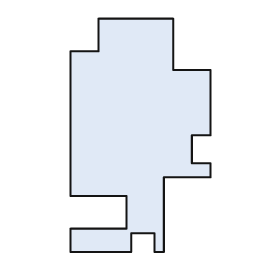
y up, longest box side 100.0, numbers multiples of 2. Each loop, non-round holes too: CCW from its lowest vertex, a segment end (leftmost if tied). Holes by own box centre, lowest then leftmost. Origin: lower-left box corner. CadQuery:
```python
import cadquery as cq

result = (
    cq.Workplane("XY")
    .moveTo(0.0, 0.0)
    .lineTo(26.0, 0.0)
    .lineTo(26.0, 8.0)
    .lineTo(36.0, 8.0)
    .lineTo(36.0, 0.0)
    .lineTo(40.0, 0.0)
    .lineTo(40.0, 32.0)
    .lineTo(60.0, 32.0)
    .lineTo(60.0, 38.0)
    .lineTo(52.0, 38.0)
    .lineTo(52.0, 50.0)
    .lineTo(60.0, 50.0)
    .lineTo(60.0, 78.0)
    .lineTo(44.0, 78.0)
    .lineTo(44.0, 100.0)
    .lineTo(12.0, 100.0)
    .lineTo(12.0, 86.0)
    .lineTo(0.0, 86.0)
    .lineTo(0.0, 24.0)
    .lineTo(24.0, 24.0)
    .lineTo(24.0, 10.0)
    .lineTo(0.0, 10.0)
    .close()
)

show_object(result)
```